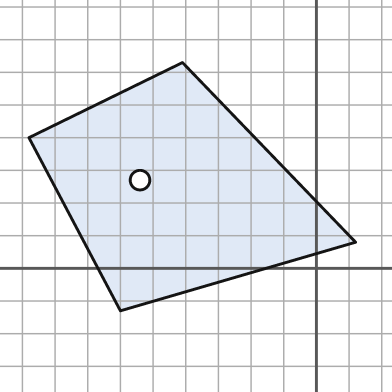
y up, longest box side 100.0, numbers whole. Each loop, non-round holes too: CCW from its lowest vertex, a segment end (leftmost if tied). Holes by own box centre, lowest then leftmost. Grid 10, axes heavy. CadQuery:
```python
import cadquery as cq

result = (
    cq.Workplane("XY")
    .moveTo(-60.0, -13.0)
    .lineTo(12.0, 8.0)
    .lineTo(-41.0, 63.0)
    .lineTo(-88.0, 40.0)
    .close()
    .moveTo(-54.0, 27.0)
    .circle(3.0)
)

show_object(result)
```